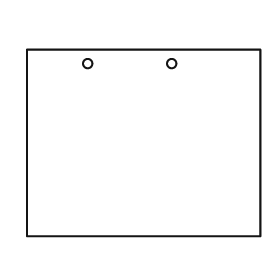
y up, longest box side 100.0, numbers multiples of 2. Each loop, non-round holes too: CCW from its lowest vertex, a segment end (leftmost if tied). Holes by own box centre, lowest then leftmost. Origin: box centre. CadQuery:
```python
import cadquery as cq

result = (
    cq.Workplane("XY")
    .moveTo(-50.0, -40.0)
    .lineTo(50.0, -40.0)
    .lineTo(50.0, 40.0)
    .lineTo(-50.0, 40.0)
    .close()
    .moveTo(-24.0, 34.0)
    .circle(2.0)
    .moveTo(12.0, 34.0)
    .circle(2.0)
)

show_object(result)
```